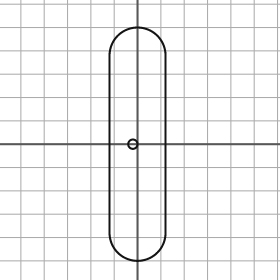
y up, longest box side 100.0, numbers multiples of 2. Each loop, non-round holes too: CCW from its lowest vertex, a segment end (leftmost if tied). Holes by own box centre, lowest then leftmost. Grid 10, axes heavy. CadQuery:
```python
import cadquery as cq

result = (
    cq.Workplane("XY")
    .moveTo(-12.0, -38.0)
    .threePointArc((0.0, -50.0), (12.0, -38.0))
    .lineTo(12.0, 38.0)
    .threePointArc((0.0, 50.0), (-12.0, 38.0))
    .close()
    .moveTo(-2.0, 0.0)
    .circle(2.0)
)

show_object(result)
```